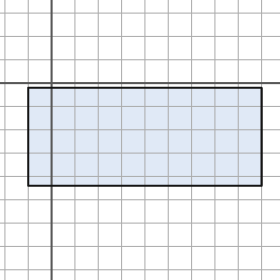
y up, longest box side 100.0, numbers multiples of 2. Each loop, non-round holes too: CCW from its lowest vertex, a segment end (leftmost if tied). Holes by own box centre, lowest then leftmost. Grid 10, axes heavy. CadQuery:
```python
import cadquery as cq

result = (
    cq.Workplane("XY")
    .moveTo(-10.0, -44.0)
    .lineTo(90.0, -44.0)
    .lineTo(90.0, -2.0)
    .lineTo(-10.0, -2.0)
    .close()
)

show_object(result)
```